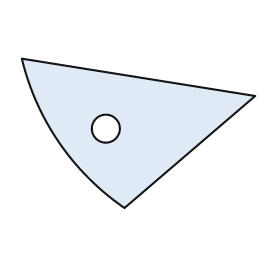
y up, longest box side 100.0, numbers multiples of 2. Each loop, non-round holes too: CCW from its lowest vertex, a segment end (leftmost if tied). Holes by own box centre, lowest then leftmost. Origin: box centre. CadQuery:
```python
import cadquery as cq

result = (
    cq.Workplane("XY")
    .moveTo(-6.0, -32.0)
    .lineTo(50.0, 16.0)
    .lineTo(-50.0, 32.0)
    .threePointArc((-34.0, -4.0), (-6.0, -32.0))
    .close()
    .moveTo(-14.0, 2.0)
    .circle(6.0)
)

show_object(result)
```